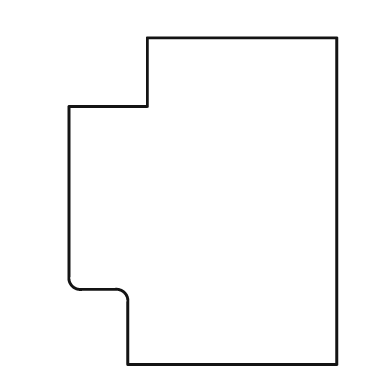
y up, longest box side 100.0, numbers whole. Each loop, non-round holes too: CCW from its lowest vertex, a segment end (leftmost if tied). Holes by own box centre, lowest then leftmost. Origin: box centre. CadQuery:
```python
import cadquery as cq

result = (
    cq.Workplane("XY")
    .moveTo(-23.0, -50.0)
    .lineTo(41.0, -50.0)
    .lineTo(41.0, 50.0)
    .lineTo(-17.0, 50.0)
    .lineTo(-17.0, 29.0)
    .lineTo(-41.0, 29.0)
    .lineTo(-41.0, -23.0)
    .threePointArc((-40.0, -26.0), (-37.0, -27.0))
    .lineTo(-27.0, -27.0)
    .threePointArc((-24.0, -28.0), (-23.0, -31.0))
    .close()
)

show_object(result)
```